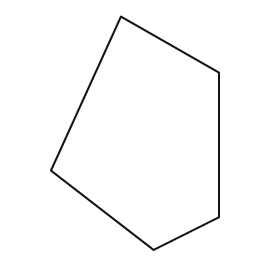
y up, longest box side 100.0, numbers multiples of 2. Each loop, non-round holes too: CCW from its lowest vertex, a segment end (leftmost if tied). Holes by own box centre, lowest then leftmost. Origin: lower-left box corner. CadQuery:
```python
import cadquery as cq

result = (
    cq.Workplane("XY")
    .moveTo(44.0, 0.0)
    .lineTo(72.0, 14.0)
    .lineTo(72.0, 76.0)
    .lineTo(30.0, 100.0)
    .lineTo(0.0, 34.0)
    .close()
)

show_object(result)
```